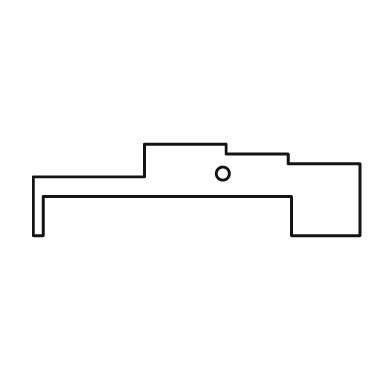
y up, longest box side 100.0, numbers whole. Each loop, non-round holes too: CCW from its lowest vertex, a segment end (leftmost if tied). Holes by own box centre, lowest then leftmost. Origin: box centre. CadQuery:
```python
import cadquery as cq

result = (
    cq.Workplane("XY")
    .moveTo(-50.0, -14.0)
    .lineTo(-47.0, -14.0)
    .lineTo(-47.0, -2.0)
    .lineTo(29.0, -2.0)
    .lineTo(29.0, -14.0)
    .lineTo(50.0, -14.0)
    .lineTo(50.0, 8.0)
    .lineTo(28.0, 8.0)
    .lineTo(28.0, 11.0)
    .lineTo(9.0, 11.0)
    .lineTo(9.0, 14.0)
    .lineTo(-16.0, 14.0)
    .lineTo(-16.0, 4.0)
    .lineTo(-50.0, 4.0)
    .close()
    .moveTo(8.0, 5.0)
    .circle(2.0)
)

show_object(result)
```